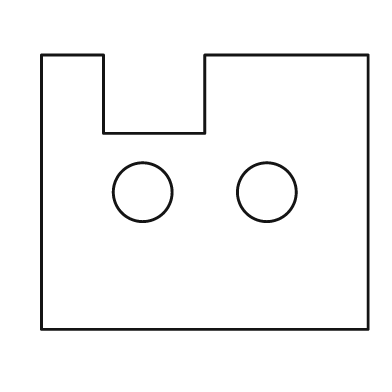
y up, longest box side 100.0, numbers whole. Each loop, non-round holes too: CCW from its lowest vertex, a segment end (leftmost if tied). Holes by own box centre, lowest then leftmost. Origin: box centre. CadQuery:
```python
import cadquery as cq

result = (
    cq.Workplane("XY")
    .moveTo(-50.0, -42.0)
    .lineTo(50.0, -42.0)
    .lineTo(50.0, 42.0)
    .lineTo(0.0, 42.0)
    .lineTo(0.0, 18.0)
    .lineTo(-31.0, 18.0)
    .lineTo(-31.0, 42.0)
    .lineTo(-50.0, 42.0)
    .close()
    .moveTo(-19.0, 0.0)
    .circle(9.0)
    .moveTo(19.0, 0.0)
    .circle(9.0)
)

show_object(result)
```